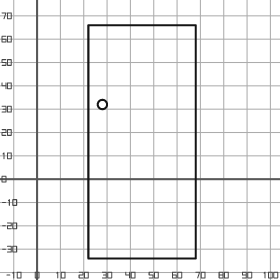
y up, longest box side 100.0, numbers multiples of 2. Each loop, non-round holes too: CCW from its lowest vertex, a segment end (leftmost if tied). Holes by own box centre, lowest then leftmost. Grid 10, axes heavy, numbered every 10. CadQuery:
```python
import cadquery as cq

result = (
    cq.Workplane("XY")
    .moveTo(22.0, -34.0)
    .lineTo(68.0, -34.0)
    .lineTo(68.0, 66.0)
    .lineTo(22.0, 66.0)
    .close()
    .moveTo(28.0, 32.0)
    .circle(2.0)
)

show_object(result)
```